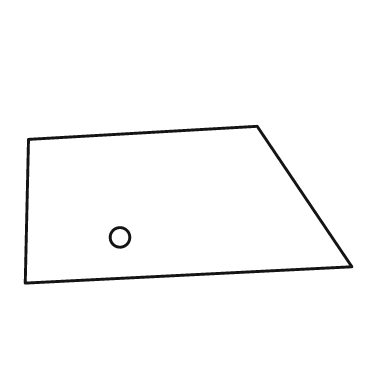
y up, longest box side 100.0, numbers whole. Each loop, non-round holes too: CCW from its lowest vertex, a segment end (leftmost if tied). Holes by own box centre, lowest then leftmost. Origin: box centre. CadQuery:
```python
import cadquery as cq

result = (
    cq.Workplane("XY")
    .moveTo(-50.0, -24.0)
    .lineTo(50.0, -19.0)
    .lineTo(21.0, 24.0)
    .lineTo(-49.0, 20.0)
    .close()
    .moveTo(-21.0, -10.0)
    .circle(3.0)
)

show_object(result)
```